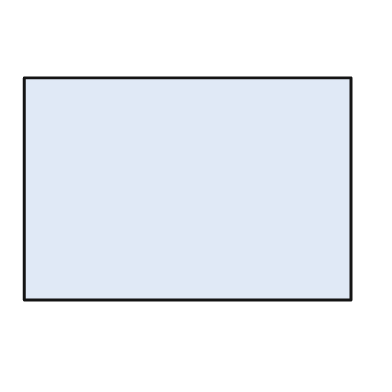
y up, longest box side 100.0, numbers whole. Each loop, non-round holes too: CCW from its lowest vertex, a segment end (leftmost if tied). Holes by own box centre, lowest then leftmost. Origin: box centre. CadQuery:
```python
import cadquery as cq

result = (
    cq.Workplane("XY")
    .moveTo(-50.0, -34.0)
    .lineTo(50.0, -34.0)
    .lineTo(50.0, 34.0)
    .lineTo(-50.0, 34.0)
    .close()
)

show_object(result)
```